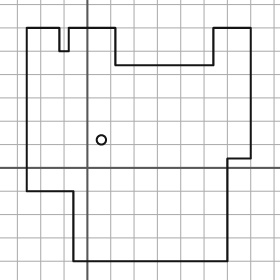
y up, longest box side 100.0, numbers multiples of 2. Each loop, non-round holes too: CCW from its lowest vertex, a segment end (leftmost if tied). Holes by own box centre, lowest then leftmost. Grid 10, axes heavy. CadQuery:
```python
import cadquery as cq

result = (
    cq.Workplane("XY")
    .moveTo(-6.0, -40.0)
    .lineTo(60.0, -40.0)
    .lineTo(60.0, 4.0)
    .lineTo(70.0, 4.0)
    .lineTo(70.0, 60.0)
    .lineTo(54.0, 60.0)
    .lineTo(54.0, 44.0)
    .lineTo(12.0, 44.0)
    .lineTo(12.0, 60.0)
    .lineTo(-8.0, 60.0)
    .lineTo(-8.0, 50.0)
    .lineTo(-12.0, 50.0)
    .lineTo(-12.0, 60.0)
    .lineTo(-26.0, 60.0)
    .lineTo(-26.0, -10.0)
    .lineTo(-6.0, -10.0)
    .close()
    .moveTo(6.0, 12.0)
    .circle(2.0)
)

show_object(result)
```